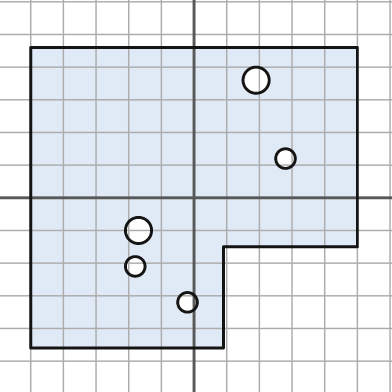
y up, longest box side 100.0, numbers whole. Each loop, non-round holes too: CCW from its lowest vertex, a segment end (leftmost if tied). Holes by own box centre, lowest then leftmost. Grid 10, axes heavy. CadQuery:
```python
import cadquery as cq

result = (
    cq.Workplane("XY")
    .moveTo(-50.0, -46.0)
    .lineTo(9.0, -46.0)
    .lineTo(9.0, -15.0)
    .lineTo(50.0, -15.0)
    .lineTo(50.0, 46.0)
    .lineTo(-50.0, 46.0)
    .close()
    .moveTo(-2.0, -32.0)
    .circle(3.0)
    .moveTo(-18.0, -21.0)
    .circle(3.0)
    .moveTo(-17.0, -10.0)
    .circle(4.0)
    .moveTo(28.0, 12.0)
    .circle(3.0)
    .moveTo(19.0, 36.0)
    .circle(4.0)
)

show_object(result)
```